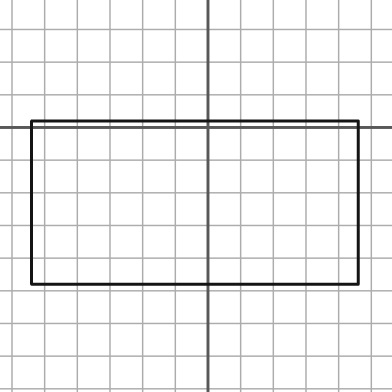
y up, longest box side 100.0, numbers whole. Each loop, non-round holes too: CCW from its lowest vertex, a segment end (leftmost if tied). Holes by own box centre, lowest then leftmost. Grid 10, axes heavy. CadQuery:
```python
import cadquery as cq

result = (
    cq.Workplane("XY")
    .moveTo(-54.0, -48.0)
    .lineTo(46.0, -48.0)
    .lineTo(46.0, 2.0)
    .lineTo(-54.0, 2.0)
    .close()
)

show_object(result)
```